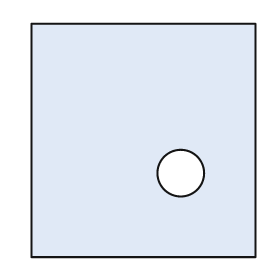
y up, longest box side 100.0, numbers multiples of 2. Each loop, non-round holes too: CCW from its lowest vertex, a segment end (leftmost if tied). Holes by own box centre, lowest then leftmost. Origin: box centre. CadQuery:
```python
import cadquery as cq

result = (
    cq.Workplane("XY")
    .moveTo(-48.0, -50.0)
    .lineTo(48.0, -50.0)
    .lineTo(48.0, 50.0)
    .lineTo(-48.0, 50.0)
    .close()
    .moveTo(16.0, -14.0)
    .circle(10.0)
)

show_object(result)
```